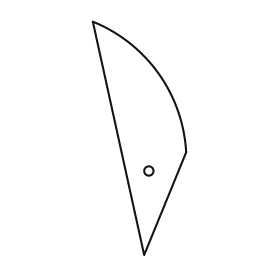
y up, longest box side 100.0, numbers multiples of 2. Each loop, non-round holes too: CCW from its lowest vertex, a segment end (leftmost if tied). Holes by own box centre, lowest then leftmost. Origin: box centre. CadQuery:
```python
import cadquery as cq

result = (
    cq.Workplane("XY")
    .moveTo(2.0, -50.0)
    .lineTo(20.0, -6.0)
    .threePointArc((8.0, 28.0), (-20.0, 50.0))
    .close()
    .moveTo(4.0, -14.0)
    .circle(2.0)
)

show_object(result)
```